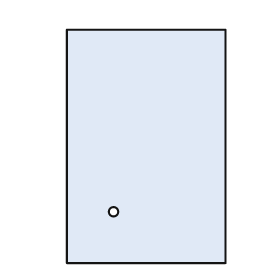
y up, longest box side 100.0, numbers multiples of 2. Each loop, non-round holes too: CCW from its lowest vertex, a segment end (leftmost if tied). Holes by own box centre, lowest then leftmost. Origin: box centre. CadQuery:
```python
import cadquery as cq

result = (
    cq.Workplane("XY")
    .moveTo(-34.0, -50.0)
    .lineTo(34.0, -50.0)
    .lineTo(34.0, 50.0)
    .lineTo(-34.0, 50.0)
    .close()
    .moveTo(-14.0, -28.0)
    .circle(2.0)
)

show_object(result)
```